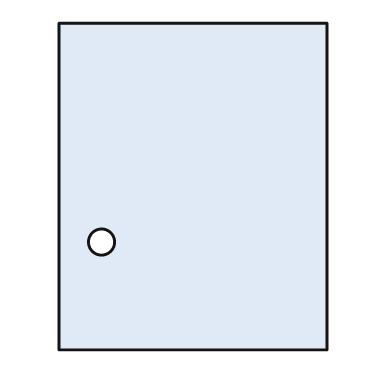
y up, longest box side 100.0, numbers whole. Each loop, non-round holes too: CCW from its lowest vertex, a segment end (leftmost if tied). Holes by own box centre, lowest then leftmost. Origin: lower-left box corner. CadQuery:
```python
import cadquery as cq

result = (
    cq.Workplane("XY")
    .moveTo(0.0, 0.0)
    .lineTo(82.0, 0.0)
    .lineTo(82.0, 100.0)
    .lineTo(0.0, 100.0)
    .close()
    .moveTo(13.0, 33.0)
    .circle(4.0)
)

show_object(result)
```